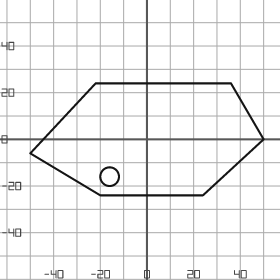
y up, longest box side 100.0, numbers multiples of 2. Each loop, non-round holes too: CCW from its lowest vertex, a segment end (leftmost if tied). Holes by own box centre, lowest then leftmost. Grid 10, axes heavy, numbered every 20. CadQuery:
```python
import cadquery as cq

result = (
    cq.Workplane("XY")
    .moveTo(-20.0, -24.0)
    .lineTo(24.0, -24.0)
    .lineTo(50.0, 0.0)
    .lineTo(36.0, 24.0)
    .lineTo(-22.0, 24.0)
    .lineTo(-50.0, -6.0)
    .close()
    .moveTo(-16.0, -16.0)
    .circle(4.0)
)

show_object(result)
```